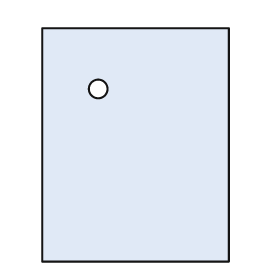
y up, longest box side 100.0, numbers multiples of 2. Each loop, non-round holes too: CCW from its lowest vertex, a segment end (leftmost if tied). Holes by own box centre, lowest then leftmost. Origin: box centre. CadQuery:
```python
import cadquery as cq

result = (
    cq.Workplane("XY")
    .moveTo(-40.0, -50.0)
    .lineTo(40.0, -50.0)
    .lineTo(40.0, 50.0)
    .lineTo(-40.0, 50.0)
    .close()
    .moveTo(-16.0, 24.0)
    .circle(4.0)
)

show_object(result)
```